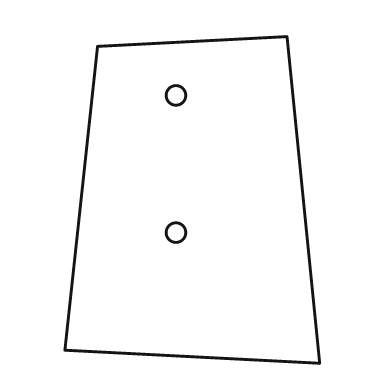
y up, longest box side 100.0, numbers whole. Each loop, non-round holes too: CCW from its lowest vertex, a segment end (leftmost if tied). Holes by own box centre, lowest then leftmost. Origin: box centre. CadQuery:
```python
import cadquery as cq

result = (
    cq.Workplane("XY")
    .moveTo(39.0, -50.0)
    .lineTo(29.0, 50.0)
    .lineTo(-29.0, 47.0)
    .lineTo(-39.0, -46.0)
    .close()
    .moveTo(-5.0, -10.0)
    .circle(3.0)
    .moveTo(-5.0, 32.0)
    .circle(3.0)
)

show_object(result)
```